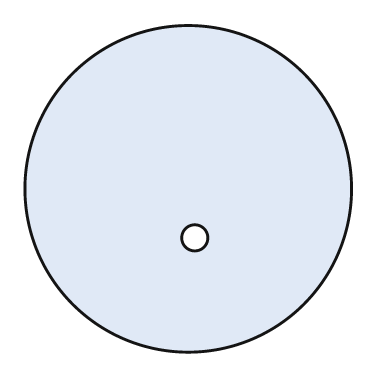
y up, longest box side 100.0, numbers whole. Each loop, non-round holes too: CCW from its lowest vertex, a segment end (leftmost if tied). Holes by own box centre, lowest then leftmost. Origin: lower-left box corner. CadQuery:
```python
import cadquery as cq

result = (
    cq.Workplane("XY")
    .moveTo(50.0, 50.0)
    .circle(50.0)
    .moveTo(52.0, 35.0)
    .circle(4.0)
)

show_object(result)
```